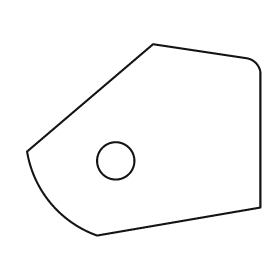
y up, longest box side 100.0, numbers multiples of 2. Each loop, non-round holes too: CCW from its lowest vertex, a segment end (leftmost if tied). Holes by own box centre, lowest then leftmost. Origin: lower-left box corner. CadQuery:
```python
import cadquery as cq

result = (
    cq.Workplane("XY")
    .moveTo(30.0, 0.0)
    .lineTo(100.0, 12.0)
    .lineTo(100.0, 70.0)
    .threePointArc((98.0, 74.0), (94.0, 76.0))
    .lineTo(54.0, 82.0)
    .lineTo(0.0, 36.0)
    .threePointArc((10.0, 14.0), (30.0, 0.0))
    .close()
    .moveTo(38.0, 32.0)
    .circle(8.0)
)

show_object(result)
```